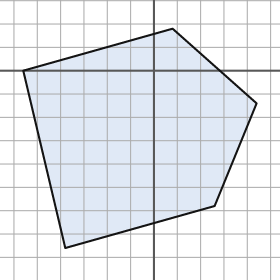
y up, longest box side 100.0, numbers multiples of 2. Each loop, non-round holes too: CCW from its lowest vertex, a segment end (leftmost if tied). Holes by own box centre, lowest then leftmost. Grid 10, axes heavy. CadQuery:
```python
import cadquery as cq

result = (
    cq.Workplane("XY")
    .moveTo(-38.0, -76.0)
    .lineTo(26.0, -58.0)
    .lineTo(44.0, -14.0)
    .lineTo(8.0, 18.0)
    .lineTo(-56.0, 0.0)
    .close()
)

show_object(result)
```